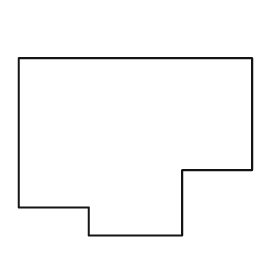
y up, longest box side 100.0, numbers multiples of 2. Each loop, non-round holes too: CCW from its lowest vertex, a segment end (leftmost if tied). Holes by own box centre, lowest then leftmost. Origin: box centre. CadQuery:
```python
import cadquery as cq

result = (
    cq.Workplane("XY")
    .moveTo(-20.0, -38.0)
    .lineTo(20.0, -38.0)
    .lineTo(20.0, -10.0)
    .lineTo(50.0, -10.0)
    .lineTo(50.0, 38.0)
    .lineTo(-50.0, 38.0)
    .lineTo(-50.0, -26.0)
    .lineTo(-20.0, -26.0)
    .close()
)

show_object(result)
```